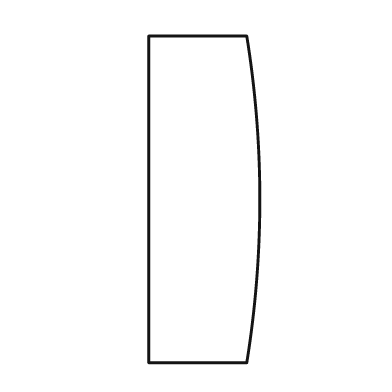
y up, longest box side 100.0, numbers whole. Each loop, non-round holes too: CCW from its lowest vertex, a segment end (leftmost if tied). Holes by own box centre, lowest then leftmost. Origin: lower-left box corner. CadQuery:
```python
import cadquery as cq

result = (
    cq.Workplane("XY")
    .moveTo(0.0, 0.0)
    .lineTo(30.0, 0.0)
    .threePointArc((34.0, 50.0), (30.0, 100.0))
    .lineTo(0.0, 100.0)
    .close()
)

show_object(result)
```